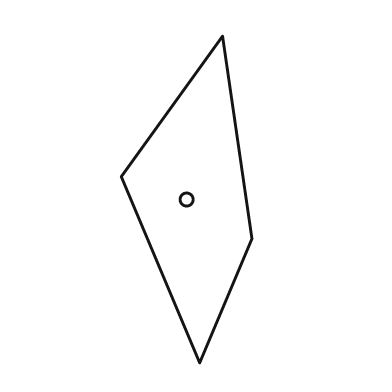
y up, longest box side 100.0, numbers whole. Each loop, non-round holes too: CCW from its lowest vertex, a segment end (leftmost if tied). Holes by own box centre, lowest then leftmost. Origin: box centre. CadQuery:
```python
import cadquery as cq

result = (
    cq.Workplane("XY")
    .moveTo(4.0, -50.0)
    .lineTo(20.0, -12.0)
    .lineTo(11.0, 50.0)
    .lineTo(-20.0, 7.0)
    .close()
    .moveTo(0.0, 0.0)
    .circle(2.0)
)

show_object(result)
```